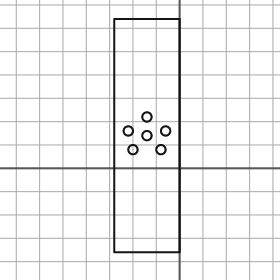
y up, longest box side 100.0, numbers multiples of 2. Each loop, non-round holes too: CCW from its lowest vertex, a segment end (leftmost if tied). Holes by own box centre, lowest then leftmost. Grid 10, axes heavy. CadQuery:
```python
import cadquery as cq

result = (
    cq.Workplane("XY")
    .moveTo(-28.0, -36.0)
    .lineTo(0.0, -36.0)
    .lineTo(0.0, 64.0)
    .lineTo(-28.0, 64.0)
    .close()
    .moveTo(-20.0, 8.0)
    .circle(2.0)
    .moveTo(-8.0, 8.0)
    .circle(2.0)
    .moveTo(-14.0, 14.0)
    .circle(2.0)
    .moveTo(-22.0, 16.0)
    .circle(2.0)
    .moveTo(-6.0, 16.0)
    .circle(2.0)
    .moveTo(-14.0, 22.0)
    .circle(2.0)
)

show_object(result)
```